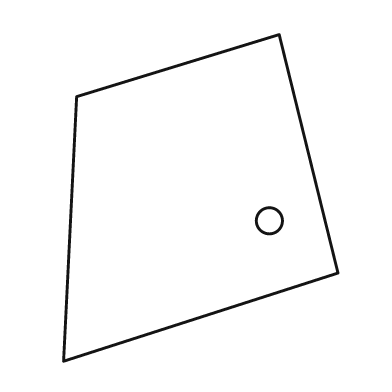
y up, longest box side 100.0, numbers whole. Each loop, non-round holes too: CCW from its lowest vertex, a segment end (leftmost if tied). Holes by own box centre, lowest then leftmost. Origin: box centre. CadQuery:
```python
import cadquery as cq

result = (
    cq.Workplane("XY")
    .moveTo(-42.0, -50.0)
    .lineTo(42.0, -23.0)
    .lineTo(24.0, 50.0)
    .lineTo(-38.0, 31.0)
    .close()
    .moveTo(21.0, -7.0)
    .circle(4.0)
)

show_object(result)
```